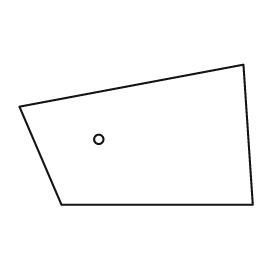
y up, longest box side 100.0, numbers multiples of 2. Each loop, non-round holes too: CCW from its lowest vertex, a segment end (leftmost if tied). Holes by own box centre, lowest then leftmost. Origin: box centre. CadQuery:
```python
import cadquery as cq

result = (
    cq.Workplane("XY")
    .moveTo(-32.0, -30.0)
    .lineTo(50.0, -30.0)
    .lineTo(46.0, 30.0)
    .lineTo(-50.0, 12.0)
    .close()
    .moveTo(-16.0, -2.0)
    .circle(2.0)
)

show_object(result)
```